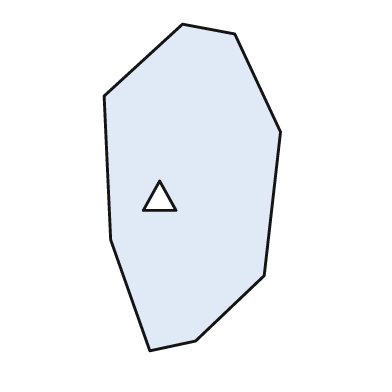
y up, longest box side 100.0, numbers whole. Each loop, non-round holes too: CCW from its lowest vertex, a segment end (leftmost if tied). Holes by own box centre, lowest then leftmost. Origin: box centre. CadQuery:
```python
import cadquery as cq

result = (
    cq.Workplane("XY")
    .moveTo(-13.0, -50.0)
    .lineTo(1.0, -47.0)
    .lineTo(22.0, -27.0)
    .lineTo(27.0, 17.0)
    .lineTo(13.0, 47.0)
    .lineTo(-3.0, 50.0)
    .lineTo(-27.0, 28.0)
    .lineTo(-25.0, -16.0)
    .close()
    .moveTo(-15.0, -7.0)
    .lineTo(-5.0, -7.0)
    .lineTo(-10.0, 2.0)
    .close()
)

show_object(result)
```